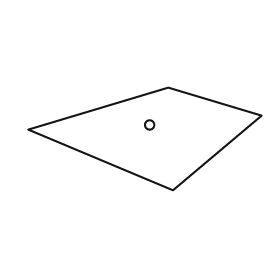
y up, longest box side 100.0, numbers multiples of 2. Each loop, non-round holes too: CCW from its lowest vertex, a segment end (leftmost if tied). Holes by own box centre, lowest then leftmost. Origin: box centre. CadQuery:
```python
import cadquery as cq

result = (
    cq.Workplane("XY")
    .moveTo(12.0, -22.0)
    .lineTo(50.0, 10.0)
    .lineTo(10.0, 22.0)
    .lineTo(-50.0, 4.0)
    .close()
    .moveTo(2.0, 6.0)
    .circle(2.0)
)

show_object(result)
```